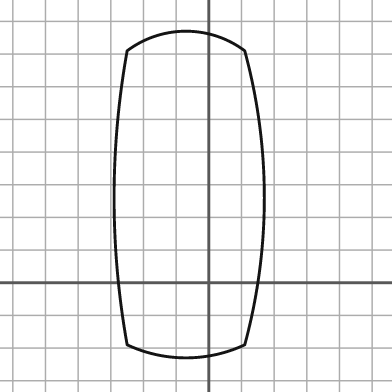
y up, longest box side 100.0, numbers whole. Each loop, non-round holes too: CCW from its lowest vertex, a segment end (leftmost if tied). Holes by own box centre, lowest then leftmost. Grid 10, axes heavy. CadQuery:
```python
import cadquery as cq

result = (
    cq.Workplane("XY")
    .moveTo(-25.0, -19.0)
    .threePointArc((-7.0, -23.0), (11.0, -19.0))
    .threePointArc((17.0, 26.0), (11.0, 71.0))
    .threePointArc((-7.0, 77.0), (-25.0, 71.0))
    .threePointArc((-29.0, 26.0), (-25.0, -19.0))
    .close()
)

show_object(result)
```